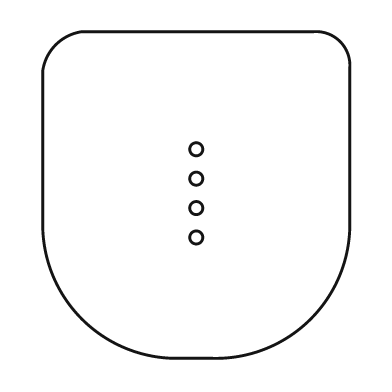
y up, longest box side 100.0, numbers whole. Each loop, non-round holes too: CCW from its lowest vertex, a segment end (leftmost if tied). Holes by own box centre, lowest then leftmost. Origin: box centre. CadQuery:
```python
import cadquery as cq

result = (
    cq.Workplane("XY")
    .moveTo(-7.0, -50.0)
    .lineTo(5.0, -50.0)
    .threePointArc((35.0, -38.0), (47.0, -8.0))
    .lineTo(47.0, 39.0)
    .threePointArc((44.0, 47.0), (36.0, 50.0))
    .lineTo(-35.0, 50.0)
    .threePointArc((-43.0, 46.0), (-47.0, 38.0))
    .lineTo(-47.0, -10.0)
    .threePointArc((-35.0, -38.0), (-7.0, -50.0))
    .close()
    .moveTo(0.0, -13.0)
    .circle(2.0)
    .moveTo(0.0, -4.0)
    .circle(2.0)
    .moveTo(0.0, 5.0)
    .circle(2.0)
    .moveTo(0.0, 14.0)
    .circle(2.0)
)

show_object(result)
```